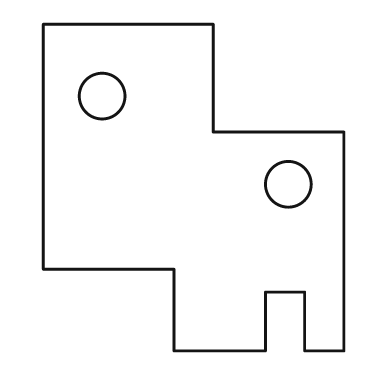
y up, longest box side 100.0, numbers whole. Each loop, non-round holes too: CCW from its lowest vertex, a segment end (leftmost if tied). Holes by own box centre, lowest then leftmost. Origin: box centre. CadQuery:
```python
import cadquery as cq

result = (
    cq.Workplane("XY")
    .moveTo(-6.0, -50.0)
    .lineTo(22.0, -50.0)
    .lineTo(22.0, -32.0)
    .lineTo(34.0, -32.0)
    .lineTo(34.0, -50.0)
    .lineTo(46.0, -50.0)
    .lineTo(46.0, 17.0)
    .lineTo(6.0, 17.0)
    .lineTo(6.0, 50.0)
    .lineTo(-46.0, 50.0)
    .lineTo(-46.0, -25.0)
    .lineTo(-6.0, -25.0)
    .close()
    .moveTo(29.0, 1.0)
    .circle(7.0)
    .moveTo(-28.0, 28.0)
    .circle(7.0)
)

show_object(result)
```